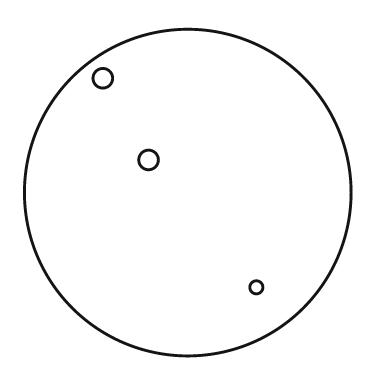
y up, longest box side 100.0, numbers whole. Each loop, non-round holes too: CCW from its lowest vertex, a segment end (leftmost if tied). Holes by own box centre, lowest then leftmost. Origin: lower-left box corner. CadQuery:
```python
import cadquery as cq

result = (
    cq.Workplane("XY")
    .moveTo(50.0, 50.0)
    .circle(50.0)
    .moveTo(71.0, 21.0)
    .circle(2.0)
    .moveTo(38.0, 60.0)
    .circle(3.0)
    .moveTo(24.0, 85.0)
    .circle(3.0)
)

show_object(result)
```